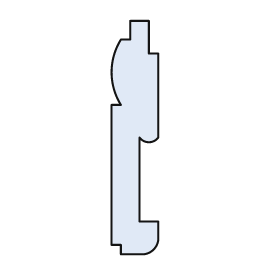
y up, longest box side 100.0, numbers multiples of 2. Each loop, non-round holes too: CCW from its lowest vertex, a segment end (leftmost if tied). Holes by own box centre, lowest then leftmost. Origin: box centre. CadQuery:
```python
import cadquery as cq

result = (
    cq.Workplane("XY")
    .moveTo(-6.0, -50.0)
    .lineTo(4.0, -50.0)
    .threePointArc((8.0, -48.0), (10.0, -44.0))
    .lineTo(10.0, -36.0)
    .lineTo(2.0, -36.0)
    .lineTo(2.0, 0.0)
    .threePointArc((6.0, -2.0), (10.0, 0.0))
    .lineTo(10.0, 36.0)
    .lineTo(6.0, 36.0)
    .lineTo(6.0, 50.0)
    .lineTo(-2.0, 50.0)
    .lineTo(-2.0, 42.0)
    .lineTo(-6.0, 42.0)
    .threePointArc((-10.0, 28.0), (-6.0, 14.0))
    .lineTo(-10.0, 14.0)
    .lineTo(-10.0, -46.0)
    .lineTo(-6.0, -46.0)
    .close()
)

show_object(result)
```